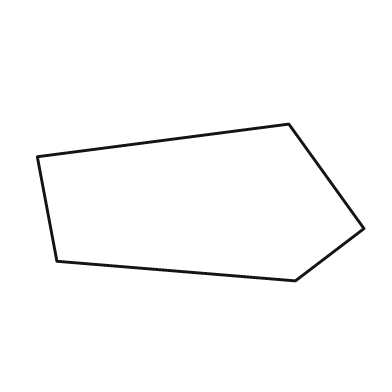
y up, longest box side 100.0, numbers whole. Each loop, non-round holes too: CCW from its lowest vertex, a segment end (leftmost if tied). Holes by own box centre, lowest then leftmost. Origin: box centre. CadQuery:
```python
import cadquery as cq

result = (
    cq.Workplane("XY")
    .moveTo(29.0, -24.0)
    .lineTo(50.0, -8.0)
    .lineTo(27.0, 24.0)
    .lineTo(-50.0, 14.0)
    .lineTo(-44.0, -18.0)
    .close()
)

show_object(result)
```